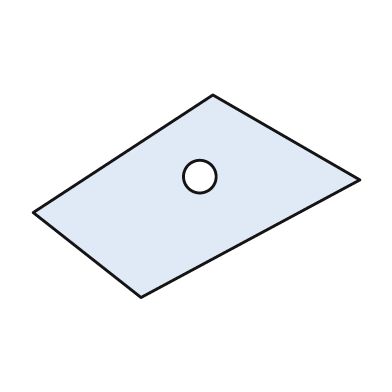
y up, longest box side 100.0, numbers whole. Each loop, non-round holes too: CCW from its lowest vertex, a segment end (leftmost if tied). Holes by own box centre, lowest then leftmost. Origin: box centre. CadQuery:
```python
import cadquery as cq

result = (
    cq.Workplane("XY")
    .moveTo(-17.0, -31.0)
    .lineTo(50.0, 5.0)
    .lineTo(5.0, 31.0)
    .lineTo(-50.0, -5.0)
    .close()
    .moveTo(1.0, 6.0)
    .circle(5.0)
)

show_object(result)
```